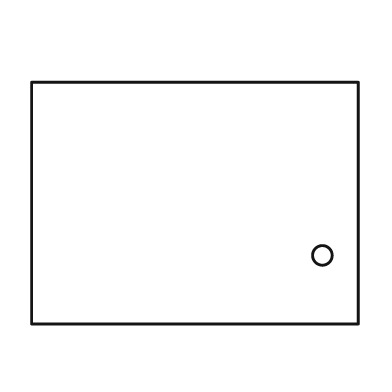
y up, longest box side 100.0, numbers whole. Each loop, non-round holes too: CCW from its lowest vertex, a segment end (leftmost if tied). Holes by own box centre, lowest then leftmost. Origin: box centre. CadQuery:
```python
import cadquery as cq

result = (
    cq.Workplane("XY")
    .moveTo(-50.0, -37.0)
    .lineTo(50.0, -37.0)
    .lineTo(50.0, 37.0)
    .lineTo(-50.0, 37.0)
    .close()
    .moveTo(39.0, -16.0)
    .circle(3.0)
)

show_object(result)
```